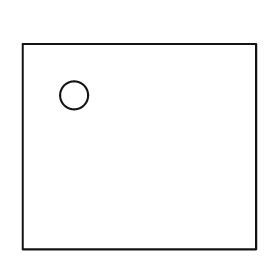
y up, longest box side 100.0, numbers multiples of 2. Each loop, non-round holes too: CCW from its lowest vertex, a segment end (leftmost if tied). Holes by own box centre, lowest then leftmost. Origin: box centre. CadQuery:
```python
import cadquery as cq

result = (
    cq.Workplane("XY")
    .moveTo(-50.0, -44.0)
    .lineTo(50.0, -44.0)
    .lineTo(50.0, 44.0)
    .lineTo(-50.0, 44.0)
    .close()
    .moveTo(-28.0, 22.0)
    .circle(6.0)
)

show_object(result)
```